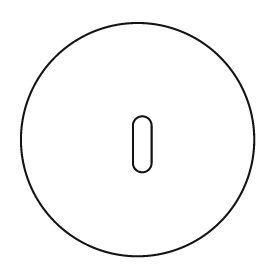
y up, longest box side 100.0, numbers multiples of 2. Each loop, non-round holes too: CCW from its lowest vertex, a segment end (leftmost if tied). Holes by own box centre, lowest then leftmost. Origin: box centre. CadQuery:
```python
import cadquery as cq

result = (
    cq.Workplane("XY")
    .moveTo(0.0, 0.0)
    .circle(50.0)
    .moveTo(-2.0, -10.0)
    .threePointArc((2.0, -14.0), (6.0, -10.0))
    .lineTo(6.0, 6.0)
    .threePointArc((2.0, 10.0), (-2.0, 6.0))
    .close()
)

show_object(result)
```